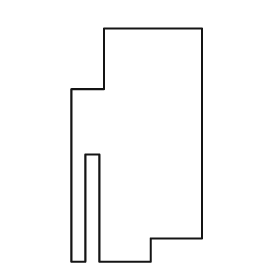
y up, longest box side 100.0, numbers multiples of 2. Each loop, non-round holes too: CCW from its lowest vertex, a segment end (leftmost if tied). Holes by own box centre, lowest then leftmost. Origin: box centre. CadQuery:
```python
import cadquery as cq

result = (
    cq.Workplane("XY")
    .moveTo(-28.0, -50.0)
    .lineTo(-22.0, -50.0)
    .lineTo(-22.0, -4.0)
    .lineTo(-16.0, -4.0)
    .lineTo(-16.0, -50.0)
    .lineTo(6.0, -50.0)
    .lineTo(6.0, -40.0)
    .lineTo(28.0, -40.0)
    .lineTo(28.0, 50.0)
    .lineTo(-14.0, 50.0)
    .lineTo(-14.0, 24.0)
    .lineTo(-28.0, 24.0)
    .close()
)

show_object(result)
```